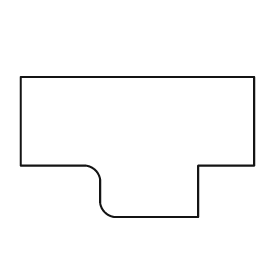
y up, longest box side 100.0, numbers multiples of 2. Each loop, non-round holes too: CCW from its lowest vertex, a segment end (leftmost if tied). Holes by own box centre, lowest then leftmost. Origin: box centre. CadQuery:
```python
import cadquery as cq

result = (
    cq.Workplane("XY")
    .moveTo(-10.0, -30.0)
    .lineTo(26.0, -30.0)
    .lineTo(26.0, -8.0)
    .lineTo(50.0, -8.0)
    .lineTo(50.0, 30.0)
    .lineTo(-50.0, 30.0)
    .lineTo(-50.0, -8.0)
    .lineTo(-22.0, -8.0)
    .threePointArc((-18.0, -10.0), (-16.0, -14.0))
    .lineTo(-16.0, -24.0)
    .threePointArc((-14.0, -28.0), (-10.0, -30.0))
    .close()
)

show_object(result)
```